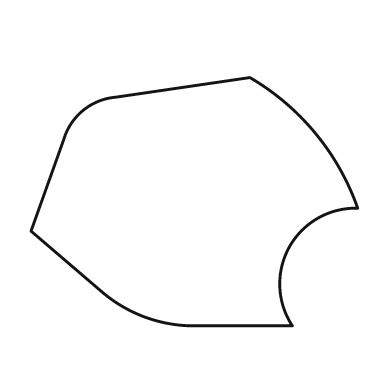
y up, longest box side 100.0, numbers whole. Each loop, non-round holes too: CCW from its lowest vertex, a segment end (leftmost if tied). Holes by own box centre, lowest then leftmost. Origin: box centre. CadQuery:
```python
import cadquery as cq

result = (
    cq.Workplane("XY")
    .moveTo(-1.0, -38.0)
    .lineTo(30.0, -38.0)
    .threePointArc((29.0, -14.0), (50.0, -2.0))
    .threePointArc((37.0, 21.0), (17.0, 38.0))
    .lineTo(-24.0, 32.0)
    .threePointArc((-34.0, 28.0), (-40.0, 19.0))
    .lineTo(-50.0, -9.0)
    .lineTo(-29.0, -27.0)
    .threePointArc((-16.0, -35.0), (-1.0, -38.0))
    .close()
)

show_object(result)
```